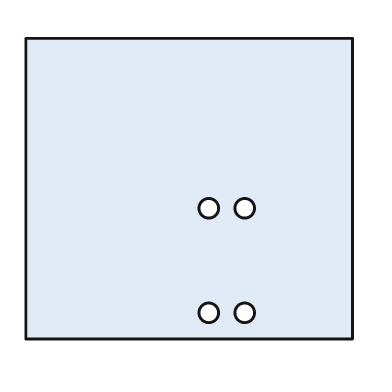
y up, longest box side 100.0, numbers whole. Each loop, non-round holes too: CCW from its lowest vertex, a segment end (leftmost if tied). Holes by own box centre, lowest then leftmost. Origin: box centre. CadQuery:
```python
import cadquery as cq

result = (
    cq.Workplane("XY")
    .moveTo(-50.0, -46.0)
    .lineTo(50.0, -46.0)
    .lineTo(50.0, 46.0)
    .lineTo(-50.0, 46.0)
    .close()
    .moveTo(6.0, -38.0)
    .circle(3.0)
    .moveTo(17.0, -38.0)
    .circle(3.0)
    .moveTo(6.0, -6.0)
    .circle(3.0)
    .moveTo(17.0, -6.0)
    .circle(3.0)
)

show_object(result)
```